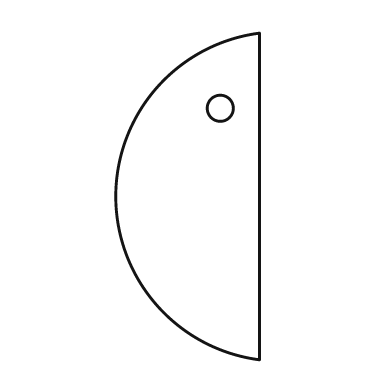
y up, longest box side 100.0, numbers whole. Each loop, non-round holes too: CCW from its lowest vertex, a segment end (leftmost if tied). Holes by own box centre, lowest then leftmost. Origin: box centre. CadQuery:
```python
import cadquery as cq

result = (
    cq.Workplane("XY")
    .moveTo(22.0, -50.0)
    .lineTo(22.0, 50.0)
    .threePointArc((-22.0, 0.0), (22.0, -50.0))
    .close()
    .moveTo(10.0, 27.0)
    .circle(4.0)
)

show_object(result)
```